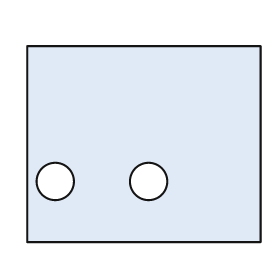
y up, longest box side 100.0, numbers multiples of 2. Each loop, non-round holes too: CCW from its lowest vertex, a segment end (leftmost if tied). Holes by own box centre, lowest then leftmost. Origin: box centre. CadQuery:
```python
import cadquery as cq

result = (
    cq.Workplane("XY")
    .moveTo(-50.0, -42.0)
    .lineTo(50.0, -42.0)
    .lineTo(50.0, 42.0)
    .lineTo(-50.0, 42.0)
    .close()
    .moveTo(-38.0, -16.0)
    .circle(8.0)
    .moveTo(2.0, -16.0)
    .circle(8.0)
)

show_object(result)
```